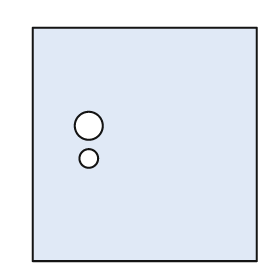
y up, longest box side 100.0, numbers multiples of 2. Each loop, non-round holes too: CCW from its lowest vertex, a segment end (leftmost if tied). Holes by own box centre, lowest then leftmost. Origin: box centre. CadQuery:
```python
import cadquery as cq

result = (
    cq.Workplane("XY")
    .moveTo(-48.0, -50.0)
    .lineTo(48.0, -50.0)
    .lineTo(48.0, 50.0)
    .lineTo(-48.0, 50.0)
    .close()
    .moveTo(-24.0, -6.0)
    .circle(4.0)
    .moveTo(-24.0, 8.0)
    .circle(6.0)
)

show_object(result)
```